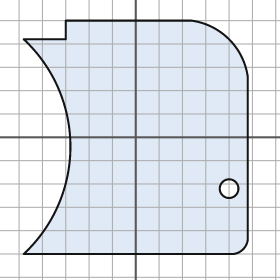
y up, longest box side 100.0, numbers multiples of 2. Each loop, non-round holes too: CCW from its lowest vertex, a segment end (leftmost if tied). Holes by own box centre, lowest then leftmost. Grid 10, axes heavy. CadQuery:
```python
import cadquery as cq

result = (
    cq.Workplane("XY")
    .moveTo(-48.0, -50.0)
    .lineTo(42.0, -50.0)
    .threePointArc((46.0, -48.0), (48.0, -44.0))
    .lineTo(48.0, 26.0)
    .threePointArc((40.0, 42.0), (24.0, 50.0))
    .lineTo(-30.0, 50.0)
    .lineTo(-30.0, 42.0)
    .lineTo(-48.0, 42.0)
    .threePointArc((-28.0, -4.0), (-48.0, -50.0))
    .close()
    .moveTo(40.0, -22.0)
    .circle(4.0)
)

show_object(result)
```